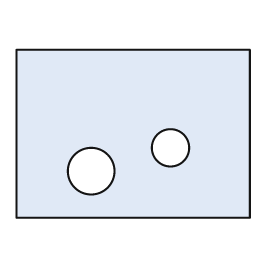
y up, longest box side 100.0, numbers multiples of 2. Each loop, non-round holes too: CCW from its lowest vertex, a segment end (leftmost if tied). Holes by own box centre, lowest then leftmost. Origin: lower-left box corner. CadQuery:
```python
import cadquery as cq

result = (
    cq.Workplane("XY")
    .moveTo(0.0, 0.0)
    .lineTo(100.0, 0.0)
    .lineTo(100.0, 72.0)
    .lineTo(0.0, 72.0)
    .close()
    .moveTo(32.0, 20.0)
    .circle(10.0)
    .moveTo(66.0, 30.0)
    .circle(8.0)
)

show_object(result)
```